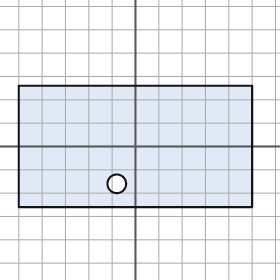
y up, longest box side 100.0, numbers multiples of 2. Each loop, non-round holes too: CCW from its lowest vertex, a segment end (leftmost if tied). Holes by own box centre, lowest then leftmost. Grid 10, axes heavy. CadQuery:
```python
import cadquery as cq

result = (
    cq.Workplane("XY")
    .moveTo(-50.0, -26.0)
    .lineTo(50.0, -26.0)
    .lineTo(50.0, 26.0)
    .lineTo(-50.0, 26.0)
    .close()
    .moveTo(-8.0, -16.0)
    .circle(4.0)
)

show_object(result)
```